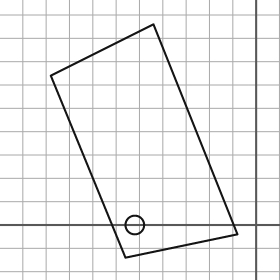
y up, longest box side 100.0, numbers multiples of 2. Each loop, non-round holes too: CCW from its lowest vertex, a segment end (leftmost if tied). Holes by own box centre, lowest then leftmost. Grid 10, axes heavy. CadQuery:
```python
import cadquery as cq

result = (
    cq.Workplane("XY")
    .moveTo(-56.0, -14.0)
    .lineTo(-8.0, -4.0)
    .lineTo(-44.0, 86.0)
    .lineTo(-88.0, 64.0)
    .close()
    .moveTo(-52.0, 0.0)
    .circle(4.0)
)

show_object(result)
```